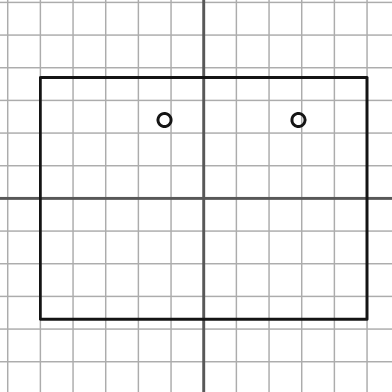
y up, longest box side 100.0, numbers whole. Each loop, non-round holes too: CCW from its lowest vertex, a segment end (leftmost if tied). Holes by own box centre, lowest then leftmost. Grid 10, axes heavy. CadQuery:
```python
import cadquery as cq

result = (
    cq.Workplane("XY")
    .moveTo(-50.0, -37.0)
    .lineTo(50.0, -37.0)
    .lineTo(50.0, 37.0)
    .lineTo(-50.0, 37.0)
    .close()
    .moveTo(-12.0, 24.0)
    .circle(2.0)
    .moveTo(29.0, 24.0)
    .circle(2.0)
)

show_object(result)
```